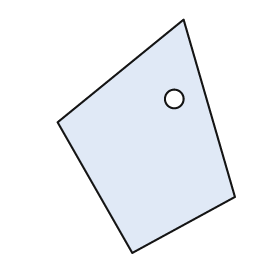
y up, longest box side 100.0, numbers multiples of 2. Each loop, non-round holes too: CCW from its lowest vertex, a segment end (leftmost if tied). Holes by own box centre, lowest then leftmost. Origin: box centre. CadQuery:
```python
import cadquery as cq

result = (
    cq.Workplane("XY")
    .moveTo(-6.0, -50.0)
    .lineTo(38.0, -26.0)
    .lineTo(16.0, 50.0)
    .lineTo(-38.0, 6.0)
    .close()
    .moveTo(12.0, 16.0)
    .circle(4.0)
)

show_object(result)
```